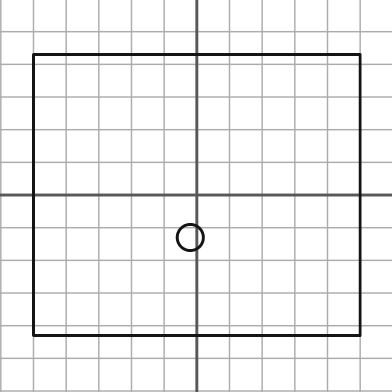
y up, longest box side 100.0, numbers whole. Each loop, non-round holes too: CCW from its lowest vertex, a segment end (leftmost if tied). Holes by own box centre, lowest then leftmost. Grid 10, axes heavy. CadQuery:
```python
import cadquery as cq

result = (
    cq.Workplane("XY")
    .moveTo(-50.0, -43.0)
    .lineTo(50.0, -43.0)
    .lineTo(50.0, 43.0)
    .lineTo(-50.0, 43.0)
    .close()
    .moveTo(-2.0, -13.0)
    .circle(4.0)
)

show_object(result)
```